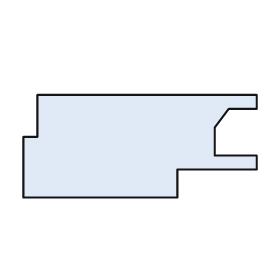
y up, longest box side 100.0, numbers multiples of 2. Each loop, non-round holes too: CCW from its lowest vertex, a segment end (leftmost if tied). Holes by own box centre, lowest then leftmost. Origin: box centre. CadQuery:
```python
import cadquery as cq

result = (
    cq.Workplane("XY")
    .moveTo(-50.0, -22.0)
    .lineTo(16.0, -22.0)
    .lineTo(16.0, -10.0)
    .lineTo(50.0, -10.0)
    .lineTo(50.0, -4.0)
    .lineTo(32.0, -4.0)
    .lineTo(32.0, 8.0)
    .lineTo(38.0, 16.0)
    .lineTo(50.0, 16.0)
    .lineTo(50.0, 22.0)
    .lineTo(-44.0, 22.0)
    .lineTo(-44.0, 4.0)
    .lineTo(-50.0, 4.0)
    .close()
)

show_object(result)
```